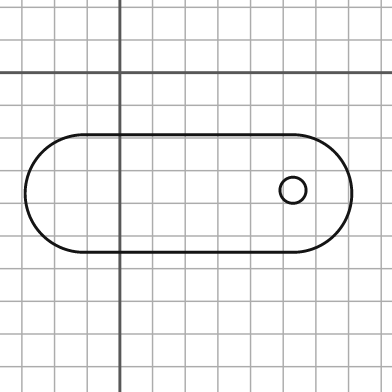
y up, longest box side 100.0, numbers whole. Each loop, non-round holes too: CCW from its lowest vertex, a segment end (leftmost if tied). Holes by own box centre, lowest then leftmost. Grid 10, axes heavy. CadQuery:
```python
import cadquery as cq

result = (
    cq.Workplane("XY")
    .moveTo(-11.0, -55.0)
    .lineTo(53.0, -55.0)
    .threePointArc((71.0, -37.0), (53.0, -19.0))
    .lineTo(-11.0, -19.0)
    .threePointArc((-29.0, -37.0), (-11.0, -55.0))
    .close()
    .moveTo(53.0, -36.0)
    .circle(4.0)
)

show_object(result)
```